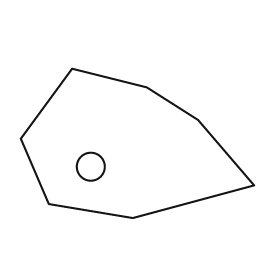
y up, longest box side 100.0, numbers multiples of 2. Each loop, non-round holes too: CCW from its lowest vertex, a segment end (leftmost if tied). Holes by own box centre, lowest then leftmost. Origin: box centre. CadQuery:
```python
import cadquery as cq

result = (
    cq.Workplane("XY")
    .moveTo(-2.0, -32.0)
    .lineTo(50.0, -18.0)
    .lineTo(26.0, 10.0)
    .lineTo(4.0, 24.0)
    .lineTo(-28.0, 32.0)
    .lineTo(-50.0, 2.0)
    .lineTo(-38.0, -26.0)
    .close()
    .moveTo(-20.0, -10.0)
    .circle(6.0)
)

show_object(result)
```